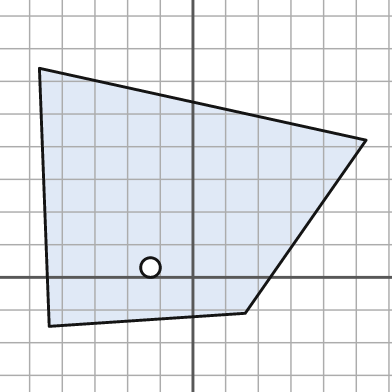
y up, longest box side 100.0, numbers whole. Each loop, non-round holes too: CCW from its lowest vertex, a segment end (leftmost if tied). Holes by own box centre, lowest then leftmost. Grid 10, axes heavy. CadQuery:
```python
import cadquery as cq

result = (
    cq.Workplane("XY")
    .moveTo(-44.0, -15.0)
    .lineTo(16.0, -11.0)
    .lineTo(53.0, 42.0)
    .lineTo(-47.0, 64.0)
    .close()
    .moveTo(-13.0, 3.0)
    .circle(3.0)
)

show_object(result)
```